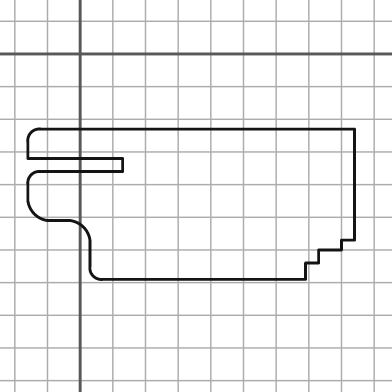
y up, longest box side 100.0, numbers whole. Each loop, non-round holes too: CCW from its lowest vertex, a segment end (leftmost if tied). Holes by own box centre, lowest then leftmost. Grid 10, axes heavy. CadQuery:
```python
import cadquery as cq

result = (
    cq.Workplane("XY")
    .moveTo(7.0, -69.0)
    .lineTo(69.0, -69.0)
    .lineTo(69.0, -64.0)
    .lineTo(73.0, -64.0)
    .lineTo(73.0, -60.0)
    .lineTo(80.0, -60.0)
    .lineTo(80.0, -57.0)
    .lineTo(84.0, -57.0)
    .lineTo(84.0, -23.0)
    .lineTo(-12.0, -23.0)
    .threePointArc((-15.0, -24.0), (-16.0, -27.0))
    .lineTo(-16.0, -32.0)
    .lineTo(13.0, -32.0)
    .lineTo(13.0, -36.0)
    .lineTo(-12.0, -36.0)
    .threePointArc((-15.0, -37.0), (-16.0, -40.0))
    .lineTo(-16.0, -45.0)
    .threePointArc((-14.0, -49.0), (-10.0, -51.0))
    .lineTo(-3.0, -51.0)
    .threePointArc((1.0, -53.0), (3.0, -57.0))
    .lineTo(3.0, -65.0)
    .threePointArc((4.0, -68.0), (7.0, -69.0))
    .close()
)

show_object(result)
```